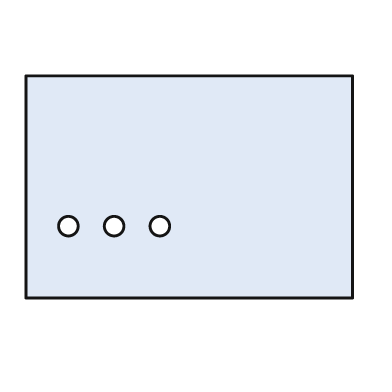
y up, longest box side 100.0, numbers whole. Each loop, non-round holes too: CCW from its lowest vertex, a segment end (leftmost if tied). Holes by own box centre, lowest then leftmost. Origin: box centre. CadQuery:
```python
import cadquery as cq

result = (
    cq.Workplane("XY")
    .moveTo(-50.0, -34.0)
    .lineTo(50.0, -34.0)
    .lineTo(50.0, 34.0)
    .lineTo(-50.0, 34.0)
    .close()
    .moveTo(-37.0, -12.0)
    .circle(3.0)
    .moveTo(-23.0, -12.0)
    .circle(3.0)
    .moveTo(-9.0, -12.0)
    .circle(3.0)
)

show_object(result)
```